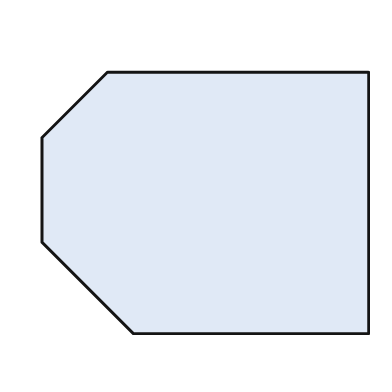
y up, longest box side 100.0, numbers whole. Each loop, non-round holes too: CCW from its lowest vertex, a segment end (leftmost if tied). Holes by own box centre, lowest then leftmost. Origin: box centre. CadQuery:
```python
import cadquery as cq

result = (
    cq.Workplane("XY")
    .moveTo(-22.0, -40.0)
    .lineTo(50.0, -40.0)
    .lineTo(50.0, 40.0)
    .lineTo(-30.0, 40.0)
    .lineTo(-50.0, 20.0)
    .lineTo(-50.0, -12.0)
    .close()
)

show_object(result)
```